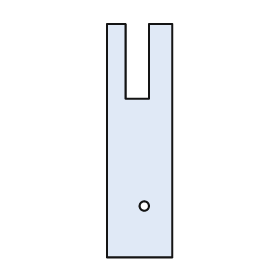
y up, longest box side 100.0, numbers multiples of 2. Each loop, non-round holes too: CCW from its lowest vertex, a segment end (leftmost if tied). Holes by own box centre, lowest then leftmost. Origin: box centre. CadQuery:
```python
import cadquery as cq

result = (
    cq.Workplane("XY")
    .moveTo(-14.0, -50.0)
    .lineTo(14.0, -50.0)
    .lineTo(14.0, 50.0)
    .lineTo(4.0, 50.0)
    .lineTo(4.0, 18.0)
    .lineTo(-6.0, 18.0)
    .lineTo(-6.0, 50.0)
    .lineTo(-14.0, 50.0)
    .close()
    .moveTo(2.0, -28.0)
    .circle(2.0)
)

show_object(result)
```